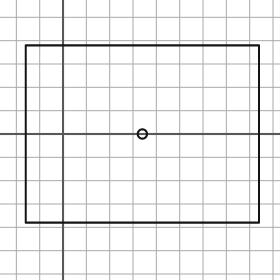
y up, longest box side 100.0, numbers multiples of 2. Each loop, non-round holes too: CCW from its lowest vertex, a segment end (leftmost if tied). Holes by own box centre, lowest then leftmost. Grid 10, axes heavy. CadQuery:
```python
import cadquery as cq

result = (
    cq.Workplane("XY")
    .moveTo(-16.0, -38.0)
    .lineTo(84.0, -38.0)
    .lineTo(84.0, 38.0)
    .lineTo(-16.0, 38.0)
    .close()
    .moveTo(34.0, 0.0)
    .circle(2.0)
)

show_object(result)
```